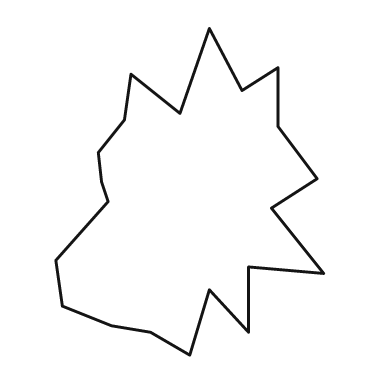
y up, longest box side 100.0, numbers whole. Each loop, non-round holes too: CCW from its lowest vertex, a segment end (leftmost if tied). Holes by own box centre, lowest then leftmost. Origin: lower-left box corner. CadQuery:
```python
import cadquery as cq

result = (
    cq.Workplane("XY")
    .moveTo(41.0, 0.0)
    .lineTo(47.0, 20.0)
    .lineTo(59.0, 7.0)
    .lineTo(59.0, 27.0)
    .lineTo(82.0, 25.0)
    .lineTo(66.0, 45.0)
    .lineTo(80.0, 54.0)
    .lineTo(68.0, 70.0)
    .lineTo(68.0, 88.0)
    .lineTo(57.0, 81.0)
    .lineTo(47.0, 100.0)
    .lineTo(38.0, 74.0)
    .lineTo(23.0, 86.0)
    .lineTo(21.0, 72.0)
    .lineTo(13.0, 62.0)
    .lineTo(14.0, 53.0)
    .lineTo(16.0, 47.0)
    .lineTo(0.0, 29.0)
    .lineTo(2.0, 15.0)
    .lineTo(17.0, 9.0)
    .lineTo(29.0, 7.0)
    .close()
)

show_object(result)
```